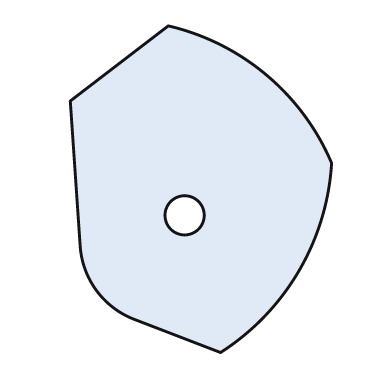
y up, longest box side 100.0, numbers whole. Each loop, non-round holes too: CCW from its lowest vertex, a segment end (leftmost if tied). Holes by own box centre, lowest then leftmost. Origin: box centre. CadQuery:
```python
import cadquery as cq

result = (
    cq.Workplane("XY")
    .moveTo(6.0, -50.0)
    .threePointArc((30.0, -25.0), (40.0, 8.0))
    .threePointArc((20.0, 35.0), (-10.0, 50.0))
    .lineTo(-40.0, 27.0)
    .lineTo(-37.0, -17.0)
    .threePointArc((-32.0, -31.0), (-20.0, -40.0))
    .close()
    .moveTo(-5.0, -8.0)
    .circle(6.0)
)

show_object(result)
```